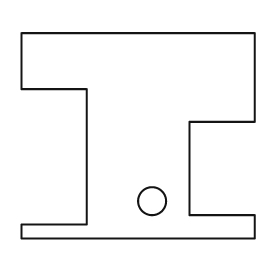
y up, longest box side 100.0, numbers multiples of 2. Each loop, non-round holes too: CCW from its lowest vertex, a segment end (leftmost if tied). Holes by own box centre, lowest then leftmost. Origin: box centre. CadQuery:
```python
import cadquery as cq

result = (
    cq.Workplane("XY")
    .moveTo(-50.0, -44.0)
    .lineTo(50.0, -44.0)
    .lineTo(50.0, -34.0)
    .lineTo(22.0, -34.0)
    .lineTo(22.0, 6.0)
    .lineTo(50.0, 6.0)
    .lineTo(50.0, 44.0)
    .lineTo(-50.0, 44.0)
    .lineTo(-50.0, 20.0)
    .lineTo(-22.0, 20.0)
    .lineTo(-22.0, -38.0)
    .lineTo(-50.0, -38.0)
    .close()
    .moveTo(6.0, -28.0)
    .circle(6.0)
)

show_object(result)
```